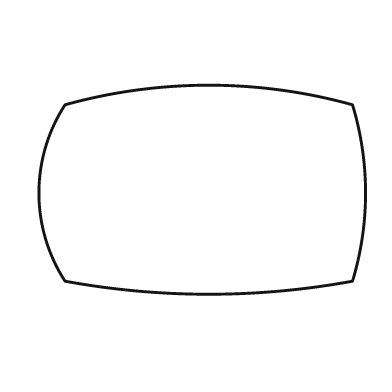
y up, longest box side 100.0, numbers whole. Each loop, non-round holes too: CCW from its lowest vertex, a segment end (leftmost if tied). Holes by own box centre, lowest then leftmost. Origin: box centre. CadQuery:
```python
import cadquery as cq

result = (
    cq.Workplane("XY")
    .moveTo(-42.0, -28.0)
    .threePointArc((2.0, -32.0), (46.0, -28.0))
    .threePointArc((50.0, -1.0), (46.0, 26.0))
    .threePointArc((2.0, 32.0), (-42.0, 26.0))
    .threePointArc((-50.0, -1.0), (-42.0, -28.0))
    .close()
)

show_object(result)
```